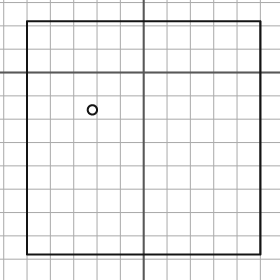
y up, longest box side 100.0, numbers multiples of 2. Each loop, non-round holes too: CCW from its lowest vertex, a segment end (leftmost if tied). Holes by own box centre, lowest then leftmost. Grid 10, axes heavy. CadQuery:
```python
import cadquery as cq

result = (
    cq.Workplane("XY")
    .moveTo(-50.0, -78.0)
    .lineTo(50.0, -78.0)
    .lineTo(50.0, 22.0)
    .lineTo(-50.0, 22.0)
    .close()
    .moveTo(-22.0, -16.0)
    .circle(2.0)
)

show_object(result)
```